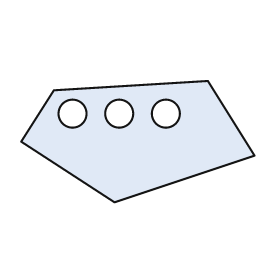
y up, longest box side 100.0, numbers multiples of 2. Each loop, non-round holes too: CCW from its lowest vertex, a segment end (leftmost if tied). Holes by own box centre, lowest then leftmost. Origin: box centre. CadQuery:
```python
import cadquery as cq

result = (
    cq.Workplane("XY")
    .moveTo(-10.0, -26.0)
    .lineTo(50.0, -6.0)
    .lineTo(30.0, 26.0)
    .lineTo(-36.0, 22.0)
    .lineTo(-50.0, 0.0)
    .close()
    .moveTo(-28.0, 12.0)
    .circle(6.0)
    .moveTo(-8.0, 12.0)
    .circle(6.0)
    .moveTo(12.0, 12.0)
    .circle(6.0)
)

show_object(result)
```